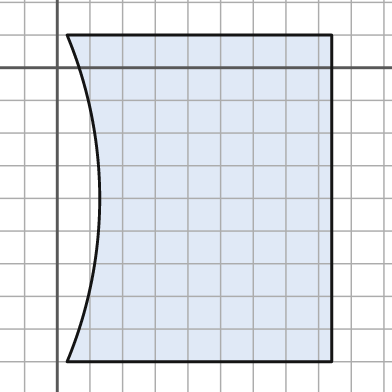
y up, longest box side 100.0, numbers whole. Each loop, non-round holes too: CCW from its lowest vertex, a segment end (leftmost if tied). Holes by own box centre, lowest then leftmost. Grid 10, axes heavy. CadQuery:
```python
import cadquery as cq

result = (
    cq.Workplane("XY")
    .moveTo(3.0, -90.0)
    .lineTo(84.0, -90.0)
    .lineTo(84.0, 10.0)
    .lineTo(3.0, 10.0)
    .threePointArc((13.0, -40.0), (3.0, -90.0))
    .close()
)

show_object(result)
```